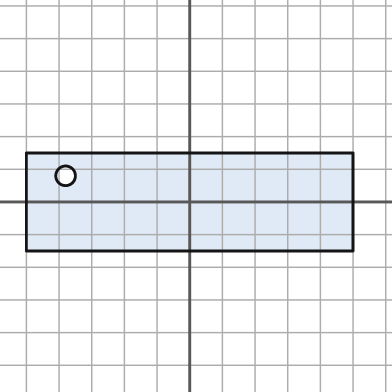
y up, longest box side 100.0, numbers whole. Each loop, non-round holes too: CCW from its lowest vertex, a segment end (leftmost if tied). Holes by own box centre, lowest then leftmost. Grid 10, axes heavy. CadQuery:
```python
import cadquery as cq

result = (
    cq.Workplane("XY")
    .moveTo(-50.0, -15.0)
    .lineTo(50.0, -15.0)
    .lineTo(50.0, 15.0)
    .lineTo(-50.0, 15.0)
    .close()
    .moveTo(-38.0, 8.0)
    .circle(3.0)
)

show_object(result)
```